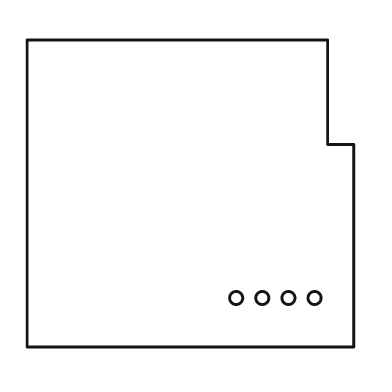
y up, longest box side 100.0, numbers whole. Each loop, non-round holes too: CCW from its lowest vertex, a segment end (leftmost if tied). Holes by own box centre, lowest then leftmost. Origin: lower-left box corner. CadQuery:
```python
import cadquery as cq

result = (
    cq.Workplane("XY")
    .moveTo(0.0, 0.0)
    .lineTo(100.0, 0.0)
    .lineTo(100.0, 62.0)
    .lineTo(92.0, 62.0)
    .lineTo(92.0, 94.0)
    .lineTo(0.0, 94.0)
    .close()
    .moveTo(64.0, 15.0)
    .circle(2.0)
    .moveTo(72.0, 15.0)
    .circle(2.0)
    .moveTo(80.0, 15.0)
    .circle(2.0)
    .moveTo(88.0, 15.0)
    .circle(2.0)
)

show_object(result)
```